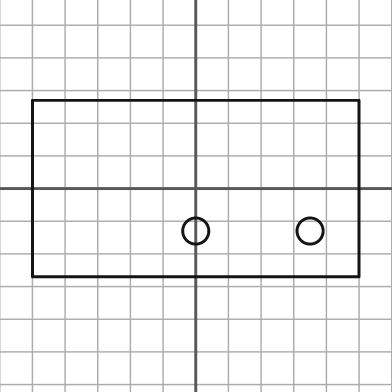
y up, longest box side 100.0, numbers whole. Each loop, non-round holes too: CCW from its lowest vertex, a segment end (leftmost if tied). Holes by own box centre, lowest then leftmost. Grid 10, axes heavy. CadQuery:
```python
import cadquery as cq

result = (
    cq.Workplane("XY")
    .moveTo(-50.0, -27.0)
    .lineTo(50.0, -27.0)
    .lineTo(50.0, 27.0)
    .lineTo(-50.0, 27.0)
    .close()
    .moveTo(0.0, -13.0)
    .circle(4.0)
    .moveTo(35.0, -13.0)
    .circle(4.0)
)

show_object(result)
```